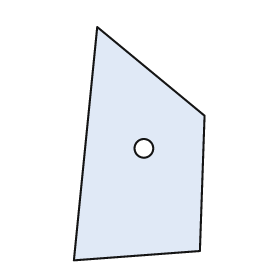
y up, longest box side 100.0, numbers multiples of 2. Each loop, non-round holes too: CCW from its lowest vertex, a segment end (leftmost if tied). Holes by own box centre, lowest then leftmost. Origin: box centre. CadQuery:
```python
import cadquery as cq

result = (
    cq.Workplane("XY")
    .moveTo(-28.0, -50.0)
    .lineTo(26.0, -46.0)
    .lineTo(28.0, 12.0)
    .lineTo(-18.0, 50.0)
    .close()
    .moveTo(2.0, -2.0)
    .circle(4.0)
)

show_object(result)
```